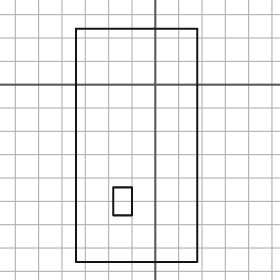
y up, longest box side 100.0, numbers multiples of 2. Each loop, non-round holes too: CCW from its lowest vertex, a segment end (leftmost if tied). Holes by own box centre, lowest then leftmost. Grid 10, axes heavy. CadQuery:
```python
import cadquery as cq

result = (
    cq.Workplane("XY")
    .moveTo(-34.0, -76.0)
    .lineTo(18.0, -76.0)
    .lineTo(18.0, 24.0)
    .lineTo(-34.0, 24.0)
    .close()
    .moveTo(-18.0, -56.0)
    .lineTo(-10.0, -56.0)
    .lineTo(-10.0, -44.0)
    .lineTo(-18.0, -44.0)
    .close()
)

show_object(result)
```